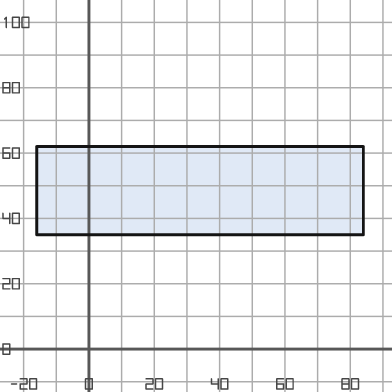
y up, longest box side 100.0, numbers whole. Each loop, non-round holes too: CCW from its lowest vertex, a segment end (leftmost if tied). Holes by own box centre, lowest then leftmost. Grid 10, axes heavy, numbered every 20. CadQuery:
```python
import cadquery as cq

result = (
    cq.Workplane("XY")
    .moveTo(-16.0, 35.0)
    .lineTo(84.0, 35.0)
    .lineTo(84.0, 62.0)
    .lineTo(-16.0, 62.0)
    .close()
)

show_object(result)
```